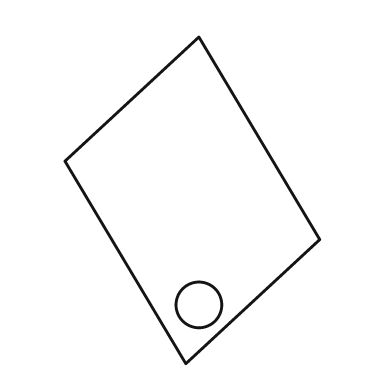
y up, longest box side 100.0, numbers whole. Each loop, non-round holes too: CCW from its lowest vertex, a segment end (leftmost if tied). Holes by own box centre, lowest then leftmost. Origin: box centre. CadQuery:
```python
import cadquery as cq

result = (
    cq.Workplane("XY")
    .moveTo(-2.0, -50.0)
    .lineTo(39.0, -12.0)
    .lineTo(2.0, 50.0)
    .lineTo(-39.0, 12.0)
    .close()
    .moveTo(2.0, -32.0)
    .circle(7.0)
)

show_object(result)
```